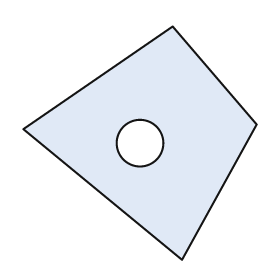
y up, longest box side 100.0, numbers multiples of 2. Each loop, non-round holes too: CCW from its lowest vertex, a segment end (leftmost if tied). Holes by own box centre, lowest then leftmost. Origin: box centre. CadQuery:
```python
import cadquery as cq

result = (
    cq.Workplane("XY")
    .moveTo(18.0, -50.0)
    .lineTo(50.0, 8.0)
    .lineTo(14.0, 50.0)
    .lineTo(-50.0, 6.0)
    .close()
    .moveTo(0.0, 0.0)
    .circle(10.0)
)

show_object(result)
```